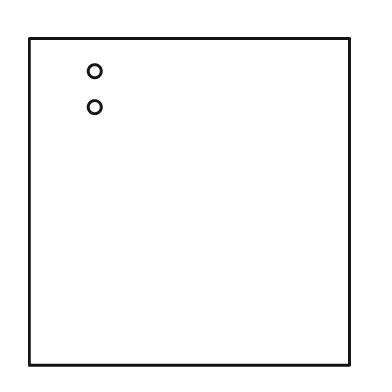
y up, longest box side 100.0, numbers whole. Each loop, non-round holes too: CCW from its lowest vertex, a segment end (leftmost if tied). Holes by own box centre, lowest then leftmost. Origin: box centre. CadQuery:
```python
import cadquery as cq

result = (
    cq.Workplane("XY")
    .moveTo(-49.0, -50.0)
    .lineTo(49.0, -50.0)
    .lineTo(49.0, 50.0)
    .lineTo(-49.0, 50.0)
    .close()
    .moveTo(-29.0, 29.0)
    .circle(2.0)
    .moveTo(-29.0, 40.0)
    .circle(2.0)
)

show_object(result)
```